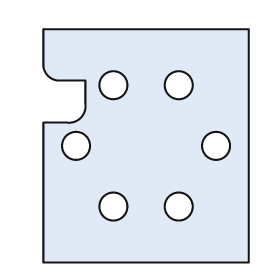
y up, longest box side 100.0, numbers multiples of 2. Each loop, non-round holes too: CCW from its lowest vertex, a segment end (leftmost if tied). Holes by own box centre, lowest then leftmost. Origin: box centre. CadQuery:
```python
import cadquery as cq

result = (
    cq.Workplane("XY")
    .moveTo(-44.0, -50.0)
    .lineTo(44.0, -50.0)
    .lineTo(44.0, 50.0)
    .lineTo(-44.0, 50.0)
    .lineTo(-44.0, 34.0)
    .threePointArc((-42.0, 30.0), (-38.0, 28.0))
    .lineTo(-26.0, 28.0)
    .lineTo(-26.0, 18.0)
    .threePointArc((-28.0, 12.0), (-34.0, 10.0))
    .lineTo(-44.0, 10.0)
    .close()
    .moveTo(-14.0, -26.0)
    .circle(6.0)
    .moveTo(14.0, -26.0)
    .circle(6.0)
    .moveTo(-30.0, 0.0)
    .circle(6.0)
    .moveTo(30.0, 0.0)
    .circle(6.0)
    .moveTo(-14.0, 26.0)
    .circle(6.0)
    .moveTo(14.0, 26.0)
    .circle(6.0)
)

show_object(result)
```